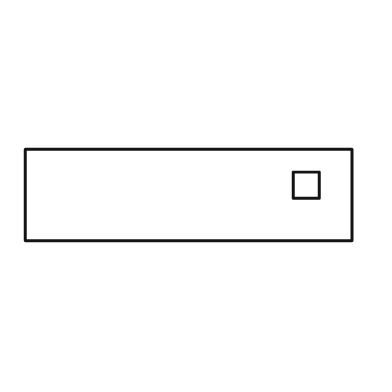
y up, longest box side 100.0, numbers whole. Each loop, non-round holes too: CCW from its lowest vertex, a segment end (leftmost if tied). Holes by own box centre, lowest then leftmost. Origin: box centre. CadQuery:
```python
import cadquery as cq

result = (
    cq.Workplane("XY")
    .moveTo(-50.0, -14.0)
    .lineTo(50.0, -14.0)
    .lineTo(50.0, 14.0)
    .lineTo(-50.0, 14.0)
    .close()
    .moveTo(32.0, -1.0)
    .lineTo(40.0, -1.0)
    .lineTo(40.0, 7.0)
    .lineTo(32.0, 7.0)
    .close()
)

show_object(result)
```